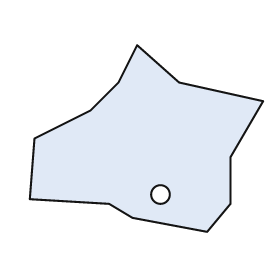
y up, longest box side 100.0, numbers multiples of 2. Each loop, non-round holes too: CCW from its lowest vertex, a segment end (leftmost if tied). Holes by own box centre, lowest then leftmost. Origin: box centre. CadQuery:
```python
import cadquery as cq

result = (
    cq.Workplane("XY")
    .moveTo(26.0, -40.0)
    .lineTo(36.0, -28.0)
    .lineTo(36.0, -8.0)
    .lineTo(50.0, 16.0)
    .lineTo(14.0, 24.0)
    .lineTo(-4.0, 40.0)
    .lineTo(-12.0, 24.0)
    .lineTo(-24.0, 12.0)
    .lineTo(-48.0, 0.0)
    .lineTo(-50.0, -26.0)
    .lineTo(-16.0, -28.0)
    .lineTo(-6.0, -34.0)
    .close()
    .moveTo(6.0, -24.0)
    .circle(4.0)
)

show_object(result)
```